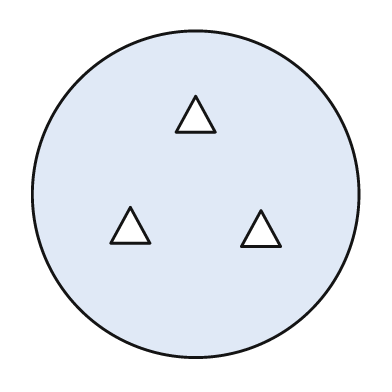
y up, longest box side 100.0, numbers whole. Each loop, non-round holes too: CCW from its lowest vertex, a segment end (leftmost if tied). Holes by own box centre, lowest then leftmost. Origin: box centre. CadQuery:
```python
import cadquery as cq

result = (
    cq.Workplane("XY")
    .moveTo(0.0, 0.0)
    .circle(50.0)
    .moveTo(14.0, -16.0)
    .lineTo(26.0, -16.0)
    .lineTo(20.0, -5.0)
    .close()
    .moveTo(-26.0, -15.0)
    .lineTo(-14.0, -15.0)
    .lineTo(-20.0, -4.0)
    .close()
    .moveTo(-6.0, 19.0)
    .lineTo(6.0, 19.0)
    .lineTo(0.0, 30.0)
    .close()
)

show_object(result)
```